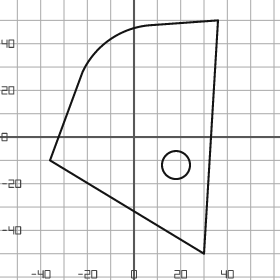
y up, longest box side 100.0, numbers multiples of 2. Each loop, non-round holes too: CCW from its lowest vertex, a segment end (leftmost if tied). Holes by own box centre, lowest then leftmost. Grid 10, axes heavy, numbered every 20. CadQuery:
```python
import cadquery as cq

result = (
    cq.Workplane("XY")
    .moveTo(30.0, -50.0)
    .lineTo(36.0, 50.0)
    .lineTo(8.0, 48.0)
    .threePointArc((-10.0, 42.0), (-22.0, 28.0))
    .lineTo(-36.0, -10.0)
    .close()
    .moveTo(18.0, -12.0)
    .circle(6.0)
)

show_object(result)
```